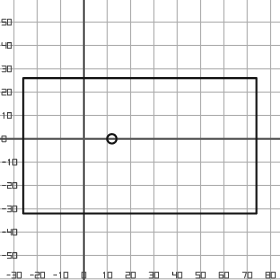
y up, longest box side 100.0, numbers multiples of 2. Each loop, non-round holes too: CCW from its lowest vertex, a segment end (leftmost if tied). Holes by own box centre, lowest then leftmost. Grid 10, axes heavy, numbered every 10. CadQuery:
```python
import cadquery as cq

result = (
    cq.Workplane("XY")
    .moveTo(-26.0, -32.0)
    .lineTo(74.0, -32.0)
    .lineTo(74.0, 26.0)
    .lineTo(-26.0, 26.0)
    .close()
    .moveTo(12.0, 0.0)
    .circle(2.0)
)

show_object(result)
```